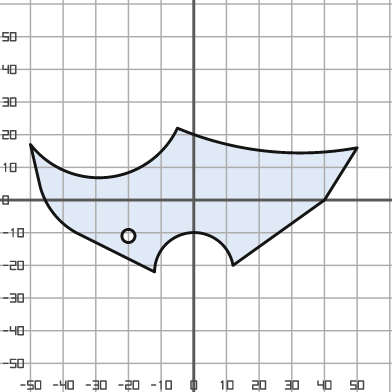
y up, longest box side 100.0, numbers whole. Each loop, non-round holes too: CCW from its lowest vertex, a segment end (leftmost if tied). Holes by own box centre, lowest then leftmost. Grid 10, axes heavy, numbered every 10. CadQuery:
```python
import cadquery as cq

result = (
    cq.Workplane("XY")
    .moveTo(-12.0, -22.0)
    .threePointArc((-1.0, -10.0), (12.0, -20.0))
    .lineTo(40.0, 0.0)
    .lineTo(50.0, 16.0)
    .threePointArc((22.0, 15.0), (-5.0, 22.0))
    .threePointArc((-26.0, 7.0), (-50.0, 17.0))
    .lineTo(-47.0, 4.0)
    .threePointArc((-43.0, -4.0), (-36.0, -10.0))
    .close()
    .moveTo(-20.0, -11.0)
    .circle(2.0)
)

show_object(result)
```